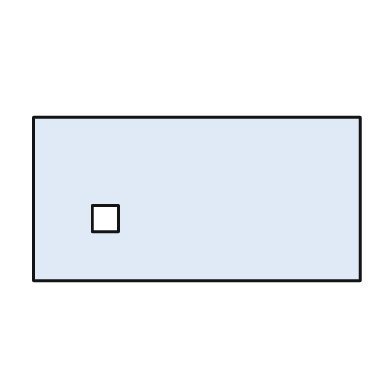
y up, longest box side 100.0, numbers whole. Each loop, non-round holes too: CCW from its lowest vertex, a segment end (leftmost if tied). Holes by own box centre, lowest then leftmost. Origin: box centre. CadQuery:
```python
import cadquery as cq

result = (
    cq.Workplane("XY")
    .moveTo(-50.0, -25.0)
    .lineTo(50.0, -25.0)
    .lineTo(50.0, 25.0)
    .lineTo(-50.0, 25.0)
    .close()
    .moveTo(-32.0, -10.0)
    .lineTo(-24.0, -10.0)
    .lineTo(-24.0, -2.0)
    .lineTo(-32.0, -2.0)
    .close()
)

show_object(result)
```